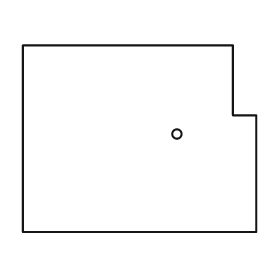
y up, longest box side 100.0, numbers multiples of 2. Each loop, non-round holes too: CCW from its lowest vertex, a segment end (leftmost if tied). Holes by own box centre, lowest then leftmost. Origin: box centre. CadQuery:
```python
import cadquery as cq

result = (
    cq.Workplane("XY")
    .moveTo(-50.0, -40.0)
    .lineTo(50.0, -40.0)
    .lineTo(50.0, 10.0)
    .lineTo(40.0, 10.0)
    .lineTo(40.0, 40.0)
    .lineTo(-50.0, 40.0)
    .close()
    .moveTo(16.0, 2.0)
    .circle(2.0)
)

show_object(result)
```